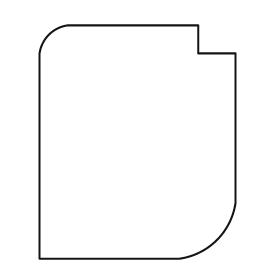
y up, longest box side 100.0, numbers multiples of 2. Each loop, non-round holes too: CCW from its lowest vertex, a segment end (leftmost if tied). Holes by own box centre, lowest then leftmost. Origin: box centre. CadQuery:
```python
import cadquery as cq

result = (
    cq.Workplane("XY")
    .moveTo(-42.0, -50.0)
    .lineTo(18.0, -50.0)
    .threePointArc((34.0, -42.0), (42.0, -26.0))
    .lineTo(42.0, 38.0)
    .lineTo(26.0, 38.0)
    .lineTo(26.0, 50.0)
    .lineTo(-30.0, 50.0)
    .threePointArc((-38.0, 46.0), (-42.0, 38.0))
    .close()
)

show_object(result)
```